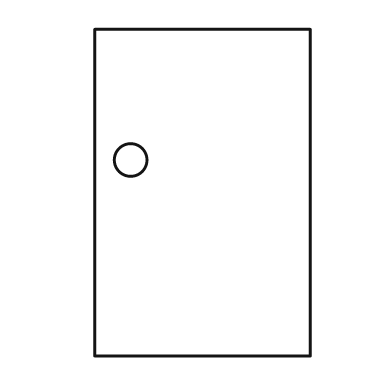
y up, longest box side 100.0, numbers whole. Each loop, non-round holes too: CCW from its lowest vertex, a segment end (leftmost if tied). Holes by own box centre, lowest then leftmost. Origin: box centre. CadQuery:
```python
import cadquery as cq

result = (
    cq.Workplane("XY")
    .moveTo(-33.0, -50.0)
    .lineTo(33.0, -50.0)
    .lineTo(33.0, 50.0)
    .lineTo(-33.0, 50.0)
    .close()
    .moveTo(-22.0, 10.0)
    .circle(5.0)
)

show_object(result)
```